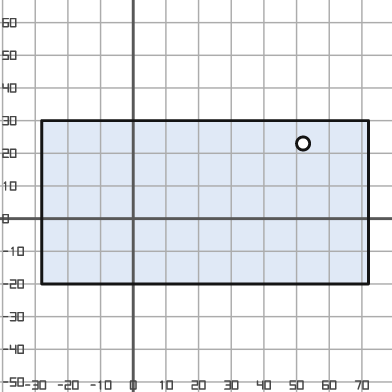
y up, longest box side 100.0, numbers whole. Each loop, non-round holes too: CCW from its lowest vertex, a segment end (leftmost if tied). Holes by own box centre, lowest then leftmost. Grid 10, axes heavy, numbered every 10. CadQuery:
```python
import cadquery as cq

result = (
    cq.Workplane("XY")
    .moveTo(-28.0, -20.0)
    .lineTo(72.0, -20.0)
    .lineTo(72.0, 30.0)
    .lineTo(-28.0, 30.0)
    .close()
    .moveTo(52.0, 23.0)
    .circle(2.0)
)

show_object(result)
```